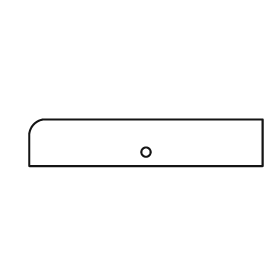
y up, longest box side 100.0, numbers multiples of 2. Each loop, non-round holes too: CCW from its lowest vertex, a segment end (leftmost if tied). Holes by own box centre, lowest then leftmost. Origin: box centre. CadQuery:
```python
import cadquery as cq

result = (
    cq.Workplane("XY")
    .moveTo(-50.0, -10.0)
    .lineTo(50.0, -10.0)
    .lineTo(50.0, 10.0)
    .lineTo(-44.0, 10.0)
    .threePointArc((-48.0, 8.0), (-50.0, 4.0))
    .close()
    .moveTo(0.0, -4.0)
    .circle(2.0)
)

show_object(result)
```